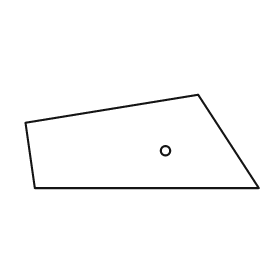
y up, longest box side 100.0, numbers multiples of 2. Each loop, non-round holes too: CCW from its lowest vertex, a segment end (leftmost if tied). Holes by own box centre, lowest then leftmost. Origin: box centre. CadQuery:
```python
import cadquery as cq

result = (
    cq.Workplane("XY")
    .moveTo(-46.0, -20.0)
    .lineTo(50.0, -20.0)
    .lineTo(24.0, 20.0)
    .lineTo(-50.0, 8.0)
    .close()
    .moveTo(10.0, -4.0)
    .circle(2.0)
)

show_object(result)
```